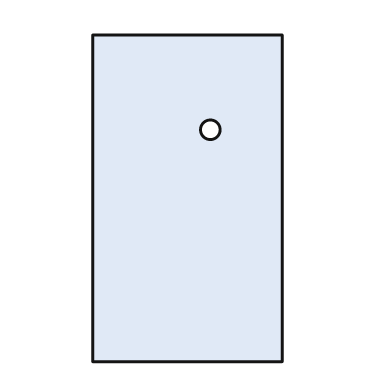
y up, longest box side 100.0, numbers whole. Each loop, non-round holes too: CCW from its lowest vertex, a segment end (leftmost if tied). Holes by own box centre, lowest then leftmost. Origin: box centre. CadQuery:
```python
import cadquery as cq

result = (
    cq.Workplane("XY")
    .moveTo(-29.0, -50.0)
    .lineTo(29.0, -50.0)
    .lineTo(29.0, 50.0)
    .lineTo(-29.0, 50.0)
    .close()
    .moveTo(7.0, 21.0)
    .circle(3.0)
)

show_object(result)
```